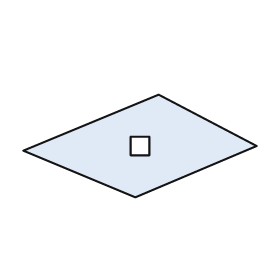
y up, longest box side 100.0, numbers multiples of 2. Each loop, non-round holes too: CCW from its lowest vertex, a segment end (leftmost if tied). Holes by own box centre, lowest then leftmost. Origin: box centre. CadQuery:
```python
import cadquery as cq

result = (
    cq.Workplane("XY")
    .moveTo(-2.0, -22.0)
    .lineTo(50.0, 0.0)
    .lineTo(8.0, 22.0)
    .lineTo(-50.0, -2.0)
    .close()
    .moveTo(-4.0, -4.0)
    .lineTo(4.0, -4.0)
    .lineTo(4.0, 4.0)
    .lineTo(-4.0, 4.0)
    .close()
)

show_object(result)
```